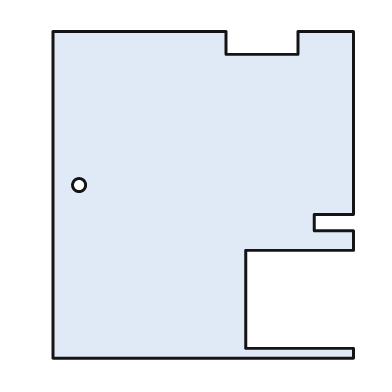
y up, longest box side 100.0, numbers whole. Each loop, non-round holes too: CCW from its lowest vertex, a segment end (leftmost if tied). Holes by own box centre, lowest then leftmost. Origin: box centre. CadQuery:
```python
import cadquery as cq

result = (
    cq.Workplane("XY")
    .moveTo(-46.0, -50.0)
    .lineTo(46.0, -50.0)
    .lineTo(46.0, -47.0)
    .lineTo(13.0, -47.0)
    .lineTo(13.0, -17.0)
    .lineTo(46.0, -17.0)
    .lineTo(46.0, -11.0)
    .lineTo(34.0, -11.0)
    .lineTo(34.0, -6.0)
    .lineTo(46.0, -6.0)
    .lineTo(46.0, 50.0)
    .lineTo(29.0, 50.0)
    .lineTo(29.0, 43.0)
    .lineTo(7.0, 43.0)
    .lineTo(7.0, 50.0)
    .lineTo(-46.0, 50.0)
    .close()
    .moveTo(-38.0, 3.0)
    .circle(2.0)
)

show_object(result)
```